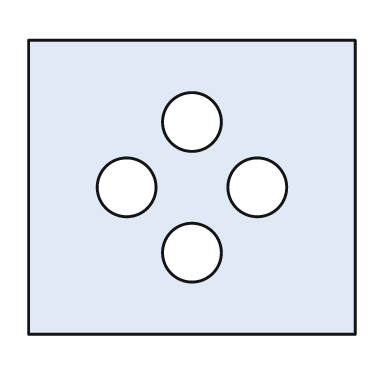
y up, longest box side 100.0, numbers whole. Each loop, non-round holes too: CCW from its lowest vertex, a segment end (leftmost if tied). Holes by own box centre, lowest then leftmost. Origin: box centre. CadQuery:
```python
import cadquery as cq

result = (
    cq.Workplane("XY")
    .moveTo(-50.0, -45.0)
    .lineTo(50.0, -45.0)
    .lineTo(50.0, 45.0)
    .lineTo(-50.0, 45.0)
    .close()
    .moveTo(0.0, -20.0)
    .circle(9.0)
    .moveTo(-20.0, 0.0)
    .circle(9.0)
    .moveTo(20.0, 0.0)
    .circle(9.0)
    .moveTo(0.0, 20.0)
    .circle(9.0)
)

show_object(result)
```